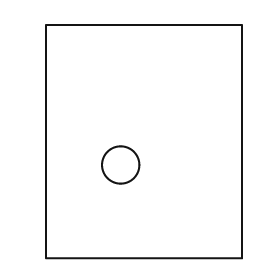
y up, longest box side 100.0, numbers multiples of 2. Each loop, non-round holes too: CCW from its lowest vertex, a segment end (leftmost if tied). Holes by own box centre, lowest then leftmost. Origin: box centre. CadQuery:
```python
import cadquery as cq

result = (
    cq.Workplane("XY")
    .moveTo(-42.0, -50.0)
    .lineTo(42.0, -50.0)
    .lineTo(42.0, 50.0)
    .lineTo(-42.0, 50.0)
    .close()
    .moveTo(-10.0, -10.0)
    .circle(8.0)
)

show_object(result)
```